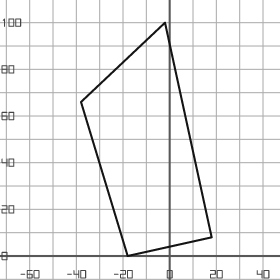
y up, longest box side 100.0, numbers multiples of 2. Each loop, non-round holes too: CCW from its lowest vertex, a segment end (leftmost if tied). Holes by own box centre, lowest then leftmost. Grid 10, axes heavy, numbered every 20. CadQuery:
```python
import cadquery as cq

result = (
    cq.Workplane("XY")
    .moveTo(-18.0, 0.0)
    .lineTo(18.0, 8.0)
    .lineTo(-2.0, 100.0)
    .lineTo(-38.0, 66.0)
    .close()
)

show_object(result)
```